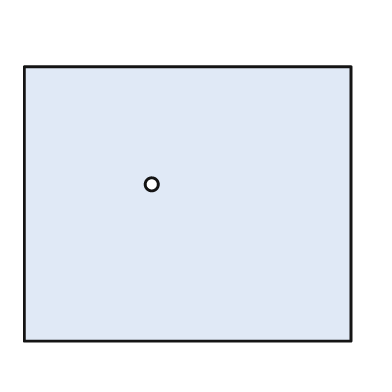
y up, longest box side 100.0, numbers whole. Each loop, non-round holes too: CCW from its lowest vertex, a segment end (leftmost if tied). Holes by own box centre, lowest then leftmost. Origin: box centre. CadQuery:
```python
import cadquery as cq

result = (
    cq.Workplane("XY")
    .moveTo(-50.0, -42.0)
    .lineTo(50.0, -42.0)
    .lineTo(50.0, 42.0)
    .lineTo(-50.0, 42.0)
    .close()
    .moveTo(-11.0, 6.0)
    .circle(2.0)
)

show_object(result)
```